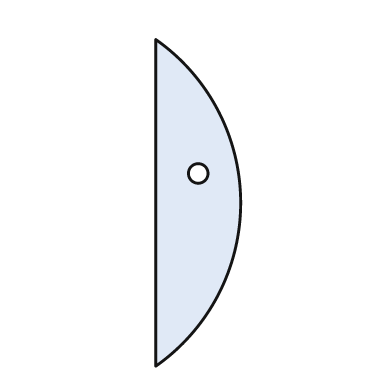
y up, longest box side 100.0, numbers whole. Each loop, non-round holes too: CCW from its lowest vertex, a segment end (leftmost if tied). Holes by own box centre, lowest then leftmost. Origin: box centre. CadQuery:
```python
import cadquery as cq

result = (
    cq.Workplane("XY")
    .moveTo(-13.0, -50.0)
    .threePointArc((13.0, 0.0), (-13.0, 50.0))
    .close()
    .moveTo(0.0, 9.0)
    .circle(3.0)
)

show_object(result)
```